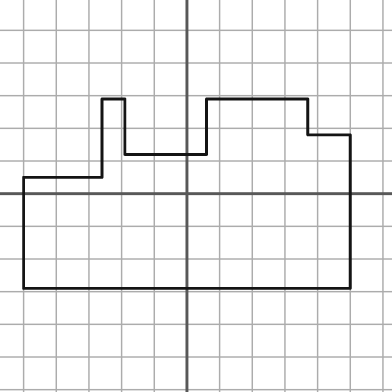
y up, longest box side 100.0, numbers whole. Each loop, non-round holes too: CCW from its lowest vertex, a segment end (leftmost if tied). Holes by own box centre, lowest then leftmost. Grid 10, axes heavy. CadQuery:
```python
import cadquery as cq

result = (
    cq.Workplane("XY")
    .moveTo(-50.0, -29.0)
    .lineTo(50.0, -29.0)
    .lineTo(50.0, 18.0)
    .lineTo(37.0, 18.0)
    .lineTo(37.0, 29.0)
    .lineTo(6.0, 29.0)
    .lineTo(6.0, 12.0)
    .lineTo(-19.0, 12.0)
    .lineTo(-19.0, 29.0)
    .lineTo(-26.0, 29.0)
    .lineTo(-26.0, 5.0)
    .lineTo(-50.0, 5.0)
    .close()
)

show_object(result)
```